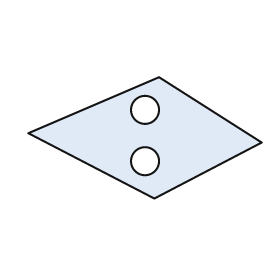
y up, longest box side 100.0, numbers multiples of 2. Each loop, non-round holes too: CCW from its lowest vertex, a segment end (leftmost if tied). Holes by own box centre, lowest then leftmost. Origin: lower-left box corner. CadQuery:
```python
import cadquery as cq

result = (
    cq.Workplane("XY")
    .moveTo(54.0, 0.0)
    .lineTo(100.0, 24.0)
    .lineTo(56.0, 52.0)
    .lineTo(0.0, 28.0)
    .close()
    .moveTo(50.0, 16.0)
    .circle(6.0)
    .moveTo(50.0, 38.0)
    .circle(6.0)
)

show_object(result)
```